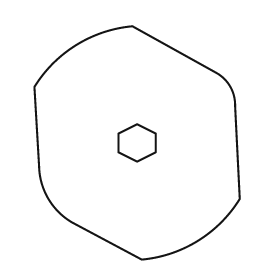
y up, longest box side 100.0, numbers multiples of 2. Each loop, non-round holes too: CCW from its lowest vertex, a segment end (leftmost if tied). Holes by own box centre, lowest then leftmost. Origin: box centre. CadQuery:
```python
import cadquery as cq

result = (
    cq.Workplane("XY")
    .moveTo(2.0, -50.0)
    .threePointArc((26.0, -42.0), (44.0, -24.0))
    .lineTo(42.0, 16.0)
    .threePointArc((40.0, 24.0), (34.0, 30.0))
    .lineTo(-2.0, 50.0)
    .threePointArc((-26.0, 42.0), (-44.0, 24.0))
    .lineTo(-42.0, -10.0)
    .threePointArc((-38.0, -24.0), (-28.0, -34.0))
    .close()
    .moveTo(0.0, -8.0)
    .lineTo(8.0, -4.0)
    .lineTo(8.0, 4.0)
    .lineTo(0.0, 8.0)
    .lineTo(-8.0, 4.0)
    .lineTo(-8.0, -4.0)
    .close()
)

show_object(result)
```